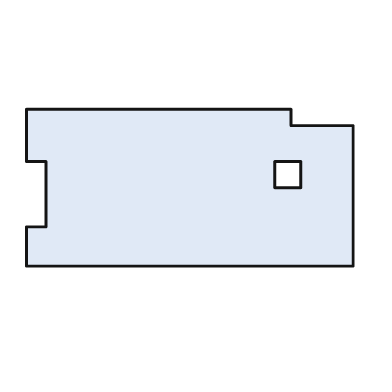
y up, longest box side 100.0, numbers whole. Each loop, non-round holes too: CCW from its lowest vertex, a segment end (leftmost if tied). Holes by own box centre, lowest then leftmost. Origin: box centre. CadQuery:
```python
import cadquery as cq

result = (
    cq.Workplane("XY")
    .moveTo(-50.0, -24.0)
    .lineTo(50.0, -24.0)
    .lineTo(50.0, 19.0)
    .lineTo(31.0, 19.0)
    .lineTo(31.0, 24.0)
    .lineTo(-50.0, 24.0)
    .lineTo(-50.0, 8.0)
    .lineTo(-44.0, 8.0)
    .lineTo(-44.0, -12.0)
    .lineTo(-50.0, -12.0)
    .close()
    .moveTo(26.0, 0.0)
    .lineTo(34.0, 0.0)
    .lineTo(34.0, 8.0)
    .lineTo(26.0, 8.0)
    .close()
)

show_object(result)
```